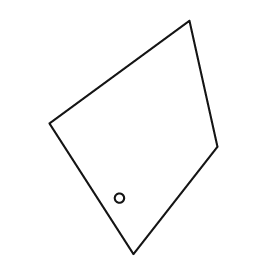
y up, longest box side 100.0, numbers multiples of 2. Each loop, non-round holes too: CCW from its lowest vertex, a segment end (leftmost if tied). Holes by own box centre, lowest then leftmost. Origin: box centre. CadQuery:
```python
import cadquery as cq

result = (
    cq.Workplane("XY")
    .moveTo(0.0, -50.0)
    .lineTo(36.0, -4.0)
    .lineTo(24.0, 50.0)
    .lineTo(-36.0, 6.0)
    .close()
    .moveTo(-6.0, -26.0)
    .circle(2.0)
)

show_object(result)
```